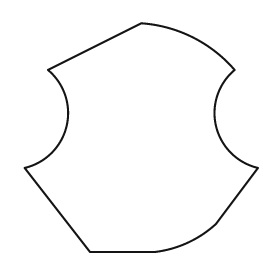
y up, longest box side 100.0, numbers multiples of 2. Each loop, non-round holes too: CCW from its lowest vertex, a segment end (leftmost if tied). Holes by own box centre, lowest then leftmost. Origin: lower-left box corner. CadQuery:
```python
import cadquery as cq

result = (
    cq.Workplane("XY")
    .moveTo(28.0, 0.0)
    .lineTo(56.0, 0.0)
    .threePointArc((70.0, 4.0), (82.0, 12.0))
    .lineTo(100.0, 36.0)
    .threePointArc((82.0, 54.0), (90.0, 78.0))
    .threePointArc((72.0, 92.0), (50.0, 98.0))
    .lineTo(10.0, 78.0)
    .threePointArc((18.0, 54.0), (0.0, 36.0))
    .close()
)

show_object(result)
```